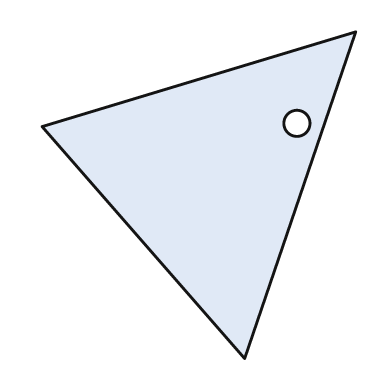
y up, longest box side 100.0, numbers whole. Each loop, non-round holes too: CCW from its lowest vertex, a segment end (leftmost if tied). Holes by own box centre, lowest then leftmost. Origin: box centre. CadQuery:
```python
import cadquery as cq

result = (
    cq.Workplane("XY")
    .moveTo(14.0, -50.0)
    .lineTo(48.0, 50.0)
    .lineTo(-48.0, 21.0)
    .close()
    .moveTo(30.0, 22.0)
    .circle(4.0)
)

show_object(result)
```